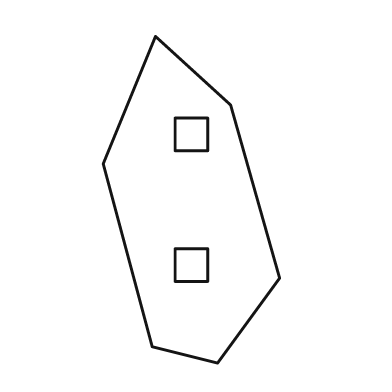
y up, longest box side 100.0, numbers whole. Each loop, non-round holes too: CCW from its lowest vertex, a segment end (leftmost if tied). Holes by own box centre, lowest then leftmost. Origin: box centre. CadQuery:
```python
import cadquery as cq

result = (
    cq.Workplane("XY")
    .moveTo(8.0, -50.0)
    .lineTo(27.0, -24.0)
    .lineTo(12.0, 29.0)
    .lineTo(-11.0, 50.0)
    .lineTo(-27.0, 11.0)
    .lineTo(-12.0, -45.0)
    .close()
    .moveTo(-5.0, -25.0)
    .lineTo(5.0, -25.0)
    .lineTo(5.0, -15.0)
    .lineTo(-5.0, -15.0)
    .close()
    .moveTo(-5.0, 15.0)
    .lineTo(5.0, 15.0)
    .lineTo(5.0, 25.0)
    .lineTo(-5.0, 25.0)
    .close()
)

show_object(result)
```